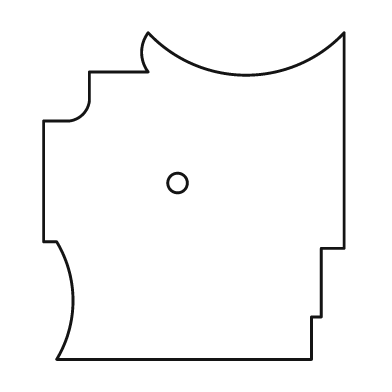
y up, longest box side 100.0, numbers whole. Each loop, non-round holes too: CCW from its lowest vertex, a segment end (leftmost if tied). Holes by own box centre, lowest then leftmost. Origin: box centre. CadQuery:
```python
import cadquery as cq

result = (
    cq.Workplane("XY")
    .moveTo(-42.0, -50.0)
    .lineTo(36.0, -50.0)
    .lineTo(36.0, -37.0)
    .lineTo(39.0, -37.0)
    .lineTo(39.0, -16.0)
    .lineTo(46.0, -16.0)
    .lineTo(46.0, 50.0)
    .threePointArc((16.0, 37.0), (-14.0, 50.0))
    .threePointArc((-16.0, 44.0), (-14.0, 38.0))
    .lineTo(-32.0, 38.0)
    .lineTo(-32.0, 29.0)
    .threePointArc((-34.0, 25.0), (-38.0, 23.0))
    .lineTo(-46.0, 23.0)
    .lineTo(-46.0, -14.0)
    .lineTo(-42.0, -14.0)
    .threePointArc((-37.0, -32.0), (-42.0, -50.0))
    .close()
    .moveTo(-5.0, 4.0)
    .circle(3.0)
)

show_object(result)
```